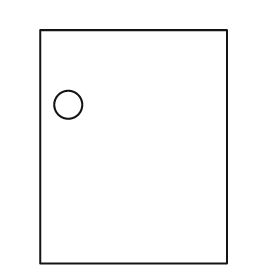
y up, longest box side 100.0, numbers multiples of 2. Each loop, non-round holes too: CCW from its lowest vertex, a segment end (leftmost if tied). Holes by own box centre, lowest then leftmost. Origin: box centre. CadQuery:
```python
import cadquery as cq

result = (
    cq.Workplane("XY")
    .moveTo(-40.0, -50.0)
    .lineTo(40.0, -50.0)
    .lineTo(40.0, 50.0)
    .lineTo(-40.0, 50.0)
    .close()
    .moveTo(-28.0, 18.0)
    .circle(6.0)
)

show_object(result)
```